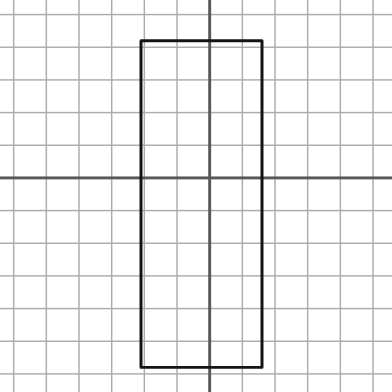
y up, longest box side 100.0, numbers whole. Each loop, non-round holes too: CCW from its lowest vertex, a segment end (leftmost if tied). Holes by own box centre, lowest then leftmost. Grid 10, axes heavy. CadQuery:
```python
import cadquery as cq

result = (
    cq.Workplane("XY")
    .moveTo(-21.0, -58.0)
    .lineTo(16.0, -58.0)
    .lineTo(16.0, 42.0)
    .lineTo(-21.0, 42.0)
    .close()
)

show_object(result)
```